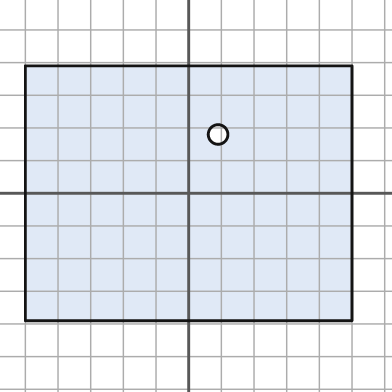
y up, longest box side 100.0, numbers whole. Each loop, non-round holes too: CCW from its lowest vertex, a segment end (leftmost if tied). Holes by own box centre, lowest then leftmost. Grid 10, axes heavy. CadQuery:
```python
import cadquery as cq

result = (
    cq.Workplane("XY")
    .moveTo(-50.0, -39.0)
    .lineTo(50.0, -39.0)
    .lineTo(50.0, 39.0)
    .lineTo(-50.0, 39.0)
    .close()
    .moveTo(9.0, 18.0)
    .circle(3.0)
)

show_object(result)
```